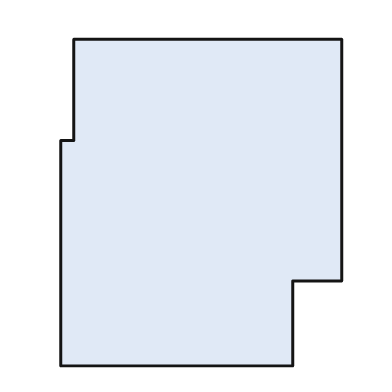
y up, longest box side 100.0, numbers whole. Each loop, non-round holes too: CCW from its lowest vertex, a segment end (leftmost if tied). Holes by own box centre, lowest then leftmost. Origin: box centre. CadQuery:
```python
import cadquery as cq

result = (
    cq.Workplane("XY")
    .moveTo(-43.0, -50.0)
    .lineTo(28.0, -50.0)
    .lineTo(28.0, -24.0)
    .lineTo(43.0, -24.0)
    .lineTo(43.0, 50.0)
    .lineTo(-39.0, 50.0)
    .lineTo(-39.0, 19.0)
    .lineTo(-43.0, 19.0)
    .close()
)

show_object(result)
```